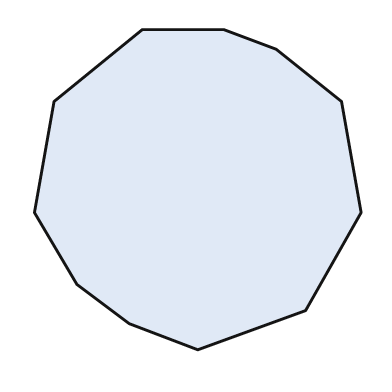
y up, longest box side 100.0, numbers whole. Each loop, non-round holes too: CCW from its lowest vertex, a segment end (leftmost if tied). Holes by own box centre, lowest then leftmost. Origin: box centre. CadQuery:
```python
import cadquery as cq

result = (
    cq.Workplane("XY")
    .moveTo(0.0, -49.0)
    .lineTo(33.0, -37.0)
    .lineTo(50.0, -7.0)
    .lineTo(44.0, 27.0)
    .lineTo(24.0, 43.0)
    .lineTo(8.0, 49.0)
    .lineTo(-17.0, 49.0)
    .lineTo(-44.0, 27.0)
    .lineTo(-50.0, -7.0)
    .lineTo(-37.0, -29.0)
    .lineTo(-21.0, -41.0)
    .close()
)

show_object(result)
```